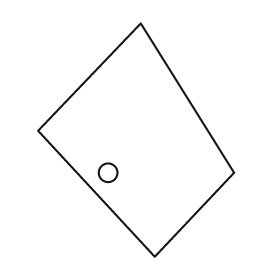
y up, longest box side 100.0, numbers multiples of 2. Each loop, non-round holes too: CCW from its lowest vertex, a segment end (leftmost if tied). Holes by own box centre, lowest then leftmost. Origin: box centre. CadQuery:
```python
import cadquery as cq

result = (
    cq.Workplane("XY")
    .moveTo(8.0, -50.0)
    .lineTo(42.0, -14.0)
    .lineTo(2.0, 50.0)
    .lineTo(-42.0, 4.0)
    .close()
    .moveTo(-12.0, -14.0)
    .circle(4.0)
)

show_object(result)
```